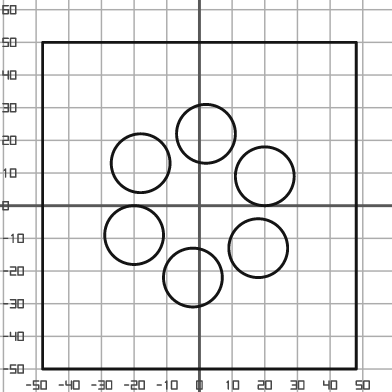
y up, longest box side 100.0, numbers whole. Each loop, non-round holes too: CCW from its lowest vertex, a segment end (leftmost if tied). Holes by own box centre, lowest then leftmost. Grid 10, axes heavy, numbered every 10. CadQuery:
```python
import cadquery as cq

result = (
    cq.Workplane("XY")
    .moveTo(-48.0, -50.0)
    .lineTo(48.0, -50.0)
    .lineTo(48.0, 50.0)
    .lineTo(-48.0, 50.0)
    .close()
    .moveTo(-2.0, -22.0)
    .circle(9.0)
    .moveTo(18.0, -13.0)
    .circle(9.0)
    .moveTo(-20.0, -9.0)
    .circle(9.0)
    .moveTo(20.0, 9.0)
    .circle(9.0)
    .moveTo(-18.0, 13.0)
    .circle(9.0)
    .moveTo(2.0, 22.0)
    .circle(9.0)
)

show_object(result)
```